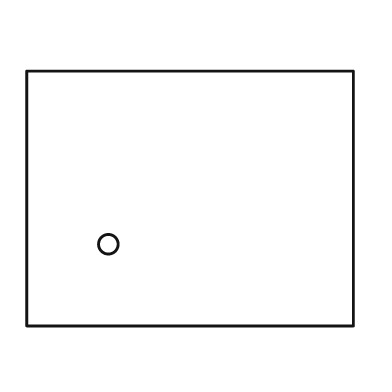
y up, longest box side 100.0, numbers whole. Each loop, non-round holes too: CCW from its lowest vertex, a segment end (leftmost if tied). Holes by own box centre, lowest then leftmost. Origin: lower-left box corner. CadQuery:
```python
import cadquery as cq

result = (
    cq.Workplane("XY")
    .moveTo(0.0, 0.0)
    .lineTo(100.0, 0.0)
    .lineTo(100.0, 78.0)
    .lineTo(0.0, 78.0)
    .close()
    .moveTo(25.0, 25.0)
    .circle(3.0)
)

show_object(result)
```